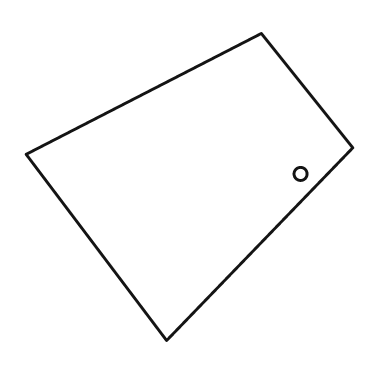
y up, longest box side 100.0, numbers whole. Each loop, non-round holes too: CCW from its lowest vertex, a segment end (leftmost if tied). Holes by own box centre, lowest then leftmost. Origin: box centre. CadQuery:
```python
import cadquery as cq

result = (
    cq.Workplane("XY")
    .moveTo(-7.0, -47.0)
    .lineTo(50.0, 12.0)
    .lineTo(22.0, 47.0)
    .lineTo(-50.0, 10.0)
    .close()
    .moveTo(34.0, 4.0)
    .circle(2.0)
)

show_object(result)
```